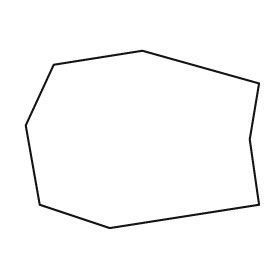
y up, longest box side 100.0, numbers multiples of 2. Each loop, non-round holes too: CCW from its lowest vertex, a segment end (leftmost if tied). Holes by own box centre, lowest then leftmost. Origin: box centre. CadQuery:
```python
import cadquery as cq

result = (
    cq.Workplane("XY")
    .moveTo(-14.0, -38.0)
    .lineTo(50.0, -28.0)
    .lineTo(46.0, 0.0)
    .lineTo(50.0, 24.0)
    .lineTo(0.0, 38.0)
    .lineTo(-38.0, 32.0)
    .lineTo(-50.0, 6.0)
    .lineTo(-44.0, -28.0)
    .close()
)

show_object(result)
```